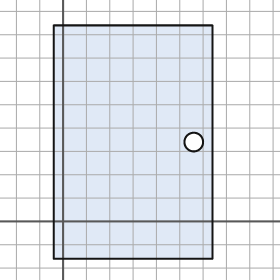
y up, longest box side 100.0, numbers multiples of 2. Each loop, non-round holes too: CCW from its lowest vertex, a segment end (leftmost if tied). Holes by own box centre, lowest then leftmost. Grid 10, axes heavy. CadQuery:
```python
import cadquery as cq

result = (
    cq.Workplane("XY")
    .moveTo(-4.0, -16.0)
    .lineTo(64.0, -16.0)
    .lineTo(64.0, 84.0)
    .lineTo(-4.0, 84.0)
    .close()
    .moveTo(56.0, 34.0)
    .circle(4.0)
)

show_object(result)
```